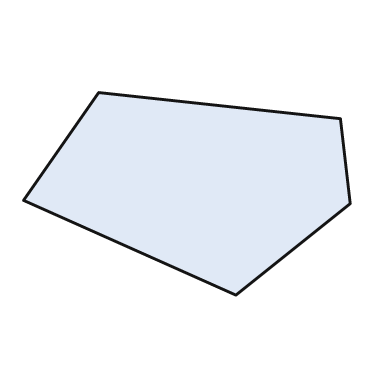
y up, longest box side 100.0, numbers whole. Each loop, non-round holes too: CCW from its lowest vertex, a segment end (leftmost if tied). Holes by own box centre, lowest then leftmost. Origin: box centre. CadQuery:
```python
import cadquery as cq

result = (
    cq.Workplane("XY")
    .moveTo(15.0, -31.0)
    .lineTo(50.0, -3.0)
    .lineTo(47.0, 23.0)
    .lineTo(-27.0, 31.0)
    .lineTo(-50.0, -2.0)
    .close()
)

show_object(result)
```